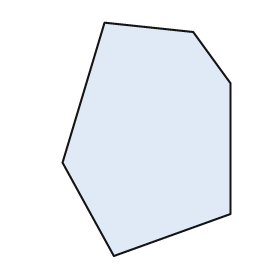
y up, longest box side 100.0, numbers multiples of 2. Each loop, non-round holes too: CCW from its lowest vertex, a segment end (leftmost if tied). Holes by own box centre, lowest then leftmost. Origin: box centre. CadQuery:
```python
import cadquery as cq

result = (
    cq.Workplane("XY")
    .moveTo(-14.0, -50.0)
    .lineTo(36.0, -32.0)
    .lineTo(36.0, 24.0)
    .lineTo(20.0, 46.0)
    .lineTo(-18.0, 50.0)
    .lineTo(-36.0, -10.0)
    .close()
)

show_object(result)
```